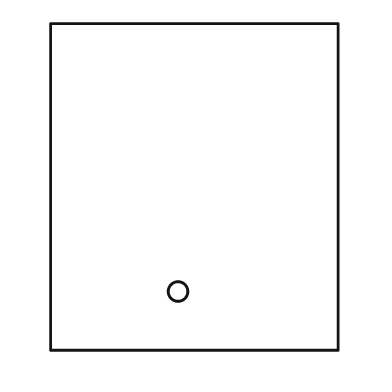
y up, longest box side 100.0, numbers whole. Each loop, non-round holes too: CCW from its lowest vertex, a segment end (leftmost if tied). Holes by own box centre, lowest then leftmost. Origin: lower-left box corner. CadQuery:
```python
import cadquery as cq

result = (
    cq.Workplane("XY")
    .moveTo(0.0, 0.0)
    .lineTo(88.0, 0.0)
    .lineTo(88.0, 100.0)
    .lineTo(0.0, 100.0)
    .close()
    .moveTo(39.0, 18.0)
    .circle(3.0)
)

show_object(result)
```